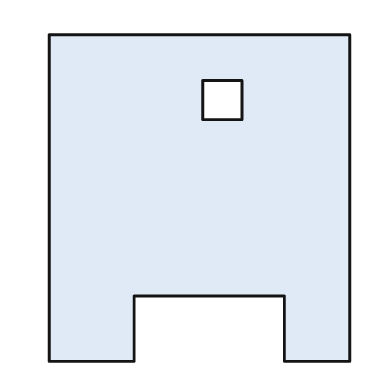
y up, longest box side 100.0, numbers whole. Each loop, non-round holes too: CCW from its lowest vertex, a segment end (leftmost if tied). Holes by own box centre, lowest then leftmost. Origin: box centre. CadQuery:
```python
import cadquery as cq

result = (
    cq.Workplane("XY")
    .moveTo(-46.0, -50.0)
    .lineTo(-20.0, -50.0)
    .lineTo(-20.0, -30.0)
    .lineTo(26.0, -30.0)
    .lineTo(26.0, -50.0)
    .lineTo(46.0, -50.0)
    .lineTo(46.0, 50.0)
    .lineTo(-46.0, 50.0)
    .close()
    .moveTo(1.0, 24.0)
    .lineTo(13.0, 24.0)
    .lineTo(13.0, 36.0)
    .lineTo(1.0, 36.0)
    .close()
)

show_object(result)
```